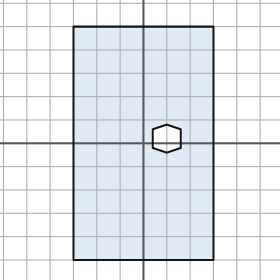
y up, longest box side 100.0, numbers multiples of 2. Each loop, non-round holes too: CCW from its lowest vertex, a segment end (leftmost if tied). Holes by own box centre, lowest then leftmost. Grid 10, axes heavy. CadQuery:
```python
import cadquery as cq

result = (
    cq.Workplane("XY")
    .moveTo(-30.0, -50.0)
    .lineTo(30.0, -50.0)
    .lineTo(30.0, 50.0)
    .lineTo(-30.0, 50.0)
    .close()
    .moveTo(10.0, -4.0)
    .lineTo(16.0, -2.0)
    .lineTo(16.0, 6.0)
    .lineTo(10.0, 8.0)
    .lineTo(4.0, 6.0)
    .lineTo(4.0, -2.0)
    .close()
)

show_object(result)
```